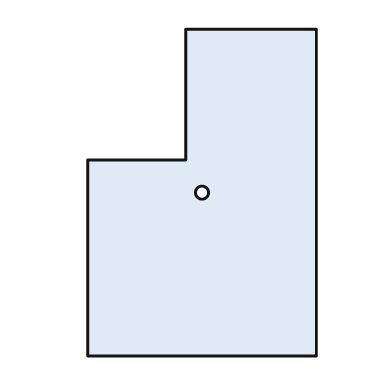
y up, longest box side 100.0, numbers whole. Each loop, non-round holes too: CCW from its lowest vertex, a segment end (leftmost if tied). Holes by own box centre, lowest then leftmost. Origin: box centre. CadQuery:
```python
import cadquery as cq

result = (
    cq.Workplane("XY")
    .moveTo(-35.0, -50.0)
    .lineTo(35.0, -50.0)
    .lineTo(35.0, 50.0)
    .lineTo(-5.0, 50.0)
    .lineTo(-5.0, 10.0)
    .lineTo(-35.0, 10.0)
    .close()
    .moveTo(0.0, 0.0)
    .circle(2.0)
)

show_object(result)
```